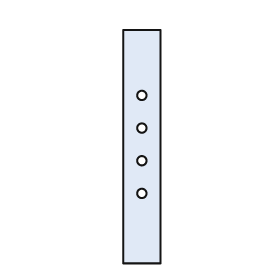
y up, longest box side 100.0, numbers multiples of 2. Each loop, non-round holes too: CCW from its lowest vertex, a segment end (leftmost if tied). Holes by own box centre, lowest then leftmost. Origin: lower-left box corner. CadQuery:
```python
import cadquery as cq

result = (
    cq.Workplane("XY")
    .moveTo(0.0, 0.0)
    .lineTo(16.0, 0.0)
    .lineTo(16.0, 100.0)
    .lineTo(0.0, 100.0)
    .close()
    .moveTo(8.0, 30.0)
    .circle(2.0)
    .moveTo(8.0, 44.0)
    .circle(2.0)
    .moveTo(8.0, 58.0)
    .circle(2.0)
    .moveTo(8.0, 72.0)
    .circle(2.0)
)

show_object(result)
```